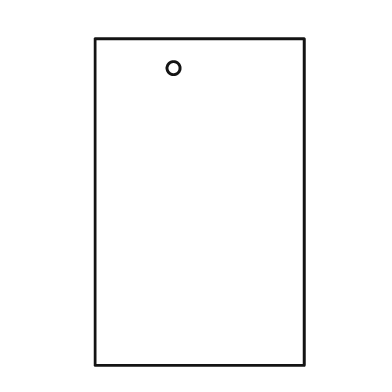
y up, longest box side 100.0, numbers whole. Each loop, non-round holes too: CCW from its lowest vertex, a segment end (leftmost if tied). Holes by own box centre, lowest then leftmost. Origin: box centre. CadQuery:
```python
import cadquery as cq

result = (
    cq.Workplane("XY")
    .moveTo(-32.0, -50.0)
    .lineTo(32.0, -50.0)
    .lineTo(32.0, 50.0)
    .lineTo(-32.0, 50.0)
    .close()
    .moveTo(-8.0, 41.0)
    .circle(2.0)
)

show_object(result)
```